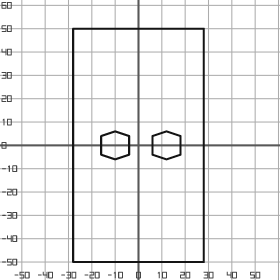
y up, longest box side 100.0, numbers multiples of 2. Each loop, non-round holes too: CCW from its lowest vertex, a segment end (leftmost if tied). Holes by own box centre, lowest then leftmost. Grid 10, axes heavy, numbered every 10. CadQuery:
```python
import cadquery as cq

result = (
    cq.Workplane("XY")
    .moveTo(-28.0, -50.0)
    .lineTo(28.0, -50.0)
    .lineTo(28.0, 50.0)
    .lineTo(-28.0, 50.0)
    .close()
    .moveTo(-10.0, -6.0)
    .lineTo(-4.0, -4.0)
    .lineTo(-4.0, 4.0)
    .lineTo(-10.0, 6.0)
    .lineTo(-16.0, 4.0)
    .lineTo(-16.0, -4.0)
    .close()
    .moveTo(12.0, -6.0)
    .lineTo(18.0, -4.0)
    .lineTo(18.0, 4.0)
    .lineTo(12.0, 6.0)
    .lineTo(6.0, 4.0)
    .lineTo(6.0, -4.0)
    .close()
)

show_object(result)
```